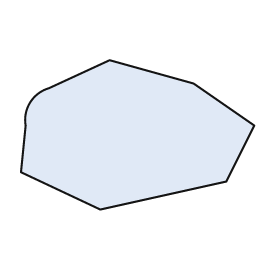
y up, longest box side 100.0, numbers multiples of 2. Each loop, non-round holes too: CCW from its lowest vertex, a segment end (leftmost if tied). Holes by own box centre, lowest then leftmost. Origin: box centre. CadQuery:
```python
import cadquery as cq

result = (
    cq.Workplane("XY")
    .moveTo(-16.0, -32.0)
    .lineTo(38.0, -20.0)
    .lineTo(50.0, 4.0)
    .lineTo(24.0, 22.0)
    .lineTo(-12.0, 32.0)
    .lineTo(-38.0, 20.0)
    .threePointArc((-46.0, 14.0), (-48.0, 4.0))
    .lineTo(-50.0, -16.0)
    .close()
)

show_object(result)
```